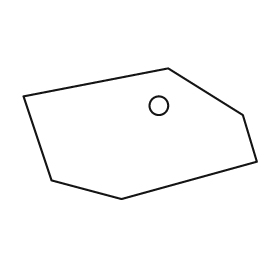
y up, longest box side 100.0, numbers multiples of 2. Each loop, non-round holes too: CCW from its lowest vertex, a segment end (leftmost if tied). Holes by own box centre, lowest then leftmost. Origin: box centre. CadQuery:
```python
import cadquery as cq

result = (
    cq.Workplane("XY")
    .moveTo(-8.0, -28.0)
    .lineTo(50.0, -12.0)
    .lineTo(44.0, 8.0)
    .lineTo(12.0, 28.0)
    .lineTo(-50.0, 16.0)
    .lineTo(-38.0, -20.0)
    .close()
    .moveTo(8.0, 12.0)
    .circle(4.0)
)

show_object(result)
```